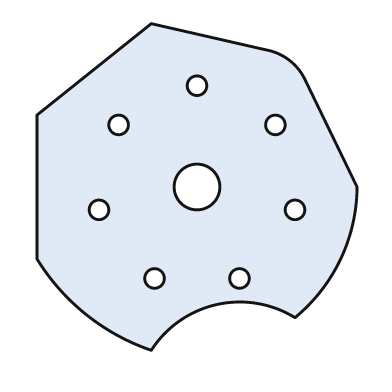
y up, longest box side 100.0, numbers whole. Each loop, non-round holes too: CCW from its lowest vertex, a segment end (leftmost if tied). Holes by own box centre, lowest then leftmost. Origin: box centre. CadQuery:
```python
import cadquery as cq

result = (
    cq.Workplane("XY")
    .moveTo(-14.0, -50.0)
    .threePointArc((6.0, -36.0), (30.0, -40.0))
    .threePointArc((44.0, -22.0), (49.0, 0.0))
    .lineTo(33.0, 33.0)
    .threePointArc((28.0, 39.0), (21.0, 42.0))
    .lineTo(-14.0, 50.0)
    .lineTo(-49.0, 22.0)
    .lineTo(-49.0, -22.0)
    .threePointArc((-34.0, -39.0), (-14.0, -50.0))
    .close()
    .moveTo(-13.0, -28.0)
    .circle(3.0)
    .moveTo(13.0, -28.0)
    .circle(3.0)
    .moveTo(-30.0, -7.0)
    .circle(3.0)
    .moveTo(30.0, -7.0)
    .circle(3.0)
    .moveTo(0.0, 0.0)
    .circle(7.0)
    .moveTo(-24.0, 19.0)
    .circle(3.0)
    .moveTo(24.0, 19.0)
    .circle(3.0)
    .moveTo(0.0, 31.0)
    .circle(3.0)
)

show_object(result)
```